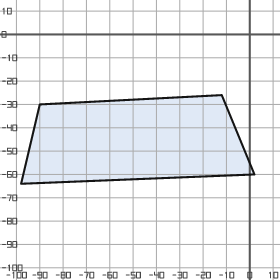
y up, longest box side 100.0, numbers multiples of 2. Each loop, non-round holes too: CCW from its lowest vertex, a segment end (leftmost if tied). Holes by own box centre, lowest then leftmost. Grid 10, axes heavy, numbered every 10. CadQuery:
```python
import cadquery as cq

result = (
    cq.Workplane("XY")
    .moveTo(-98.0, -64.0)
    .lineTo(2.0, -60.0)
    .lineTo(-12.0, -26.0)
    .lineTo(-90.0, -30.0)
    .close()
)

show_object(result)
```